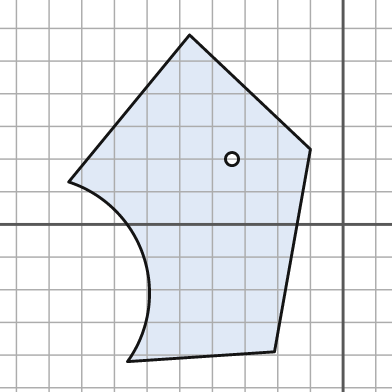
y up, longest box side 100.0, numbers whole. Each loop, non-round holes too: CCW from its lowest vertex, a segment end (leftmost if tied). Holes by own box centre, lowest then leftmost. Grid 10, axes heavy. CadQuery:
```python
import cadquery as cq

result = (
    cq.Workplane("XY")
    .moveTo(-66.0, -42.0)
    .lineTo(-21.0, -39.0)
    .lineTo(-10.0, 23.0)
    .lineTo(-47.0, 58.0)
    .lineTo(-84.0, 13.0)
    .threePointArc((-61.0, -10.0), (-66.0, -42.0))
    .close()
    .moveTo(-34.0, 20.0)
    .circle(2.0)
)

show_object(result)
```